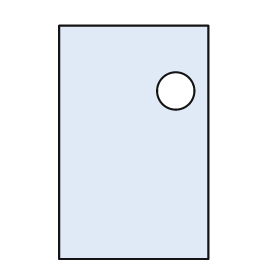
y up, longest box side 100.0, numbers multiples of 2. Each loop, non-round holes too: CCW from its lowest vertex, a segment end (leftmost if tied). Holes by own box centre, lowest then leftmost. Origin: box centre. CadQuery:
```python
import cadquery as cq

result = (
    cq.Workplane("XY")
    .moveTo(-32.0, -50.0)
    .lineTo(32.0, -50.0)
    .lineTo(32.0, 50.0)
    .lineTo(-32.0, 50.0)
    .close()
    .moveTo(18.0, 22.0)
    .circle(8.0)
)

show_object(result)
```